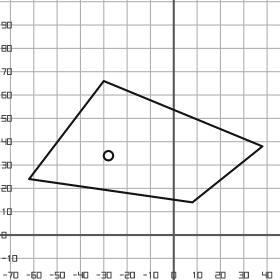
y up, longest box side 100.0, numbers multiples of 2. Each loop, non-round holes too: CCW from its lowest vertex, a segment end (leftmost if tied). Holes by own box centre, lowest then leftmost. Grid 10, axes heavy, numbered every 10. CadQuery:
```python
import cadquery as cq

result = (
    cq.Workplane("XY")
    .moveTo(8.0, 14.0)
    .lineTo(38.0, 38.0)
    .lineTo(-30.0, 66.0)
    .lineTo(-62.0, 24.0)
    .close()
    .moveTo(-28.0, 34.0)
    .circle(2.0)
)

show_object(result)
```